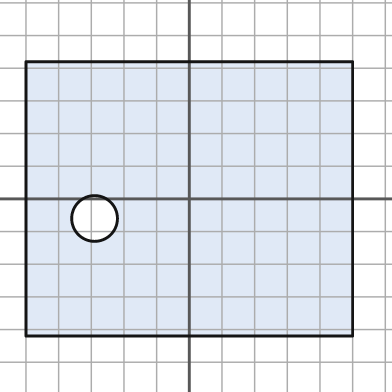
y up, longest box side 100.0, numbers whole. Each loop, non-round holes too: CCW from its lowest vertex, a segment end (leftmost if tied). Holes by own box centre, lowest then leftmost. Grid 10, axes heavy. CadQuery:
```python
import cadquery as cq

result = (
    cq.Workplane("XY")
    .moveTo(-50.0, -42.0)
    .lineTo(50.0, -42.0)
    .lineTo(50.0, 42.0)
    .lineTo(-50.0, 42.0)
    .close()
    .moveTo(-29.0, -6.0)
    .circle(7.0)
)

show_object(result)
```